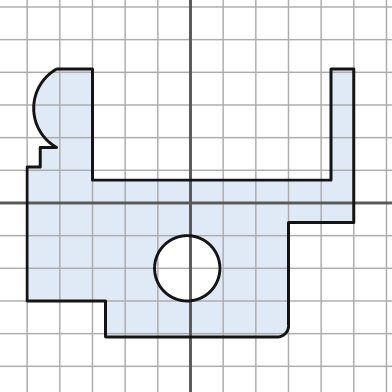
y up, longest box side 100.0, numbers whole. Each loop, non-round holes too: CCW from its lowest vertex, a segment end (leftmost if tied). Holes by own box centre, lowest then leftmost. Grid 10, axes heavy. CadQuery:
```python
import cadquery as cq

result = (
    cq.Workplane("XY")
    .moveTo(-26.0, -41.0)
    .lineTo(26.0, -41.0)
    .threePointArc((29.0, -40.0), (30.0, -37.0))
    .lineTo(30.0, -6.0)
    .lineTo(50.0, -6.0)
    .lineTo(50.0, 41.0)
    .lineTo(43.0, 41.0)
    .lineTo(43.0, 7.0)
    .lineTo(-30.0, 7.0)
    .lineTo(-30.0, 41.0)
    .lineTo(-41.0, 41.0)
    .threePointArc((-48.0, 29.0), (-41.0, 17.0))
    .lineTo(-46.0, 17.0)
    .lineTo(-46.0, 11.0)
    .lineTo(-50.0, 11.0)
    .lineTo(-50.0, -30.0)
    .lineTo(-26.0, -30.0)
    .close()
    .moveTo(-1.0, -20.0)
    .circle(10.0)
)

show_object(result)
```